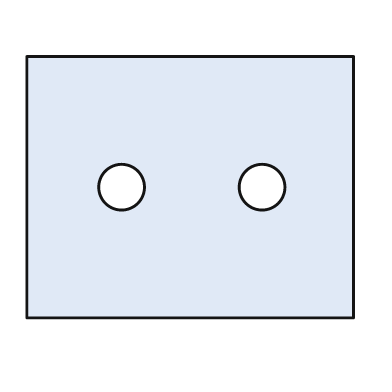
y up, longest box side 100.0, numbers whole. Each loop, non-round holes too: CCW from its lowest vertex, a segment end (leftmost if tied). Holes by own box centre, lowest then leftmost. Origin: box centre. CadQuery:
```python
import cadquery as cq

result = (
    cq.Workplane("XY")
    .moveTo(-50.0, -40.0)
    .lineTo(50.0, -40.0)
    .lineTo(50.0, 40.0)
    .lineTo(-50.0, 40.0)
    .close()
    .moveTo(-21.0, 0.0)
    .circle(7.0)
    .moveTo(22.0, 0.0)
    .circle(7.0)
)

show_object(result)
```